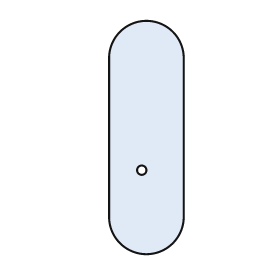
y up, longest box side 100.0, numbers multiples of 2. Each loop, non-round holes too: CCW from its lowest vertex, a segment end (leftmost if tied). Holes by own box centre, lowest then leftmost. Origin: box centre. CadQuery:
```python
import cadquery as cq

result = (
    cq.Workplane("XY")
    .moveTo(-16.0, -34.0)
    .threePointArc((0.0, -50.0), (16.0, -34.0))
    .lineTo(16.0, 34.0)
    .threePointArc((0.0, 50.0), (-16.0, 34.0))
    .close()
    .moveTo(-2.0, -14.0)
    .circle(2.0)
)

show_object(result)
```